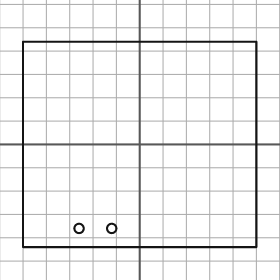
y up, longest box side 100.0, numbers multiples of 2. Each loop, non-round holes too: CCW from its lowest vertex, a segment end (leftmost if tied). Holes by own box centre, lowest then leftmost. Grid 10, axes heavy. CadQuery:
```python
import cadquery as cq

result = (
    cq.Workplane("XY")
    .moveTo(-50.0, -44.0)
    .lineTo(50.0, -44.0)
    .lineTo(50.0, 44.0)
    .lineTo(-50.0, 44.0)
    .close()
    .moveTo(-26.0, -36.0)
    .circle(2.0)
    .moveTo(-12.0, -36.0)
    .circle(2.0)
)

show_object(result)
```